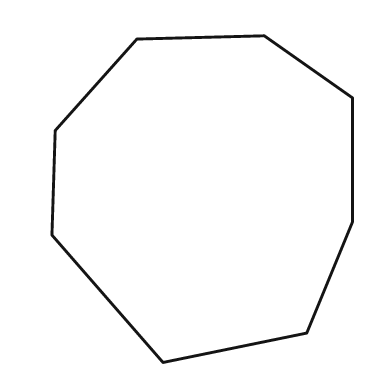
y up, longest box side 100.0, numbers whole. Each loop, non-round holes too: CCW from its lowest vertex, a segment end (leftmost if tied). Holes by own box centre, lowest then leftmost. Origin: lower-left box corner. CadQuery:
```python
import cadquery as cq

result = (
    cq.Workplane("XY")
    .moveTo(34.0, 0.0)
    .lineTo(78.0, 9.0)
    .lineTo(92.0, 43.0)
    .lineTo(92.0, 81.0)
    .lineTo(65.0, 100.0)
    .lineTo(26.0, 99.0)
    .lineTo(1.0, 71.0)
    .lineTo(0.0, 39.0)
    .close()
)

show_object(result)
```